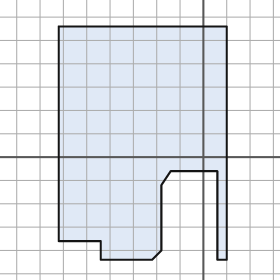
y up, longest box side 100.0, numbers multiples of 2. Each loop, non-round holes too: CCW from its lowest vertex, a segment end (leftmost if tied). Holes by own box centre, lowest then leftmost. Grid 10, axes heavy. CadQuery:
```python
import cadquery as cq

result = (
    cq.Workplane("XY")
    .moveTo(-44.0, -44.0)
    .lineTo(-22.0, -44.0)
    .lineTo(-18.0, -40.0)
    .lineTo(-18.0, -12.0)
    .lineTo(-14.0, -6.0)
    .lineTo(6.0, -6.0)
    .lineTo(6.0, -44.0)
    .lineTo(10.0, -44.0)
    .lineTo(10.0, 56.0)
    .lineTo(-62.0, 56.0)
    .lineTo(-62.0, -36.0)
    .lineTo(-44.0, -36.0)
    .close()
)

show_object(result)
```